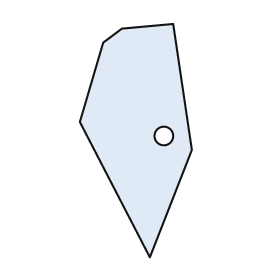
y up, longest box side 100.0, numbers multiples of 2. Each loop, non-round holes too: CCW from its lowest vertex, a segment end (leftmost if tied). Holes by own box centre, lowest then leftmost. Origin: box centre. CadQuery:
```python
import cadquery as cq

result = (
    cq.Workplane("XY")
    .moveTo(6.0, -50.0)
    .lineTo(24.0, -4.0)
    .lineTo(16.0, 50.0)
    .lineTo(-6.0, 48.0)
    .lineTo(-14.0, 42.0)
    .lineTo(-24.0, 8.0)
    .close()
    .moveTo(12.0, 2.0)
    .circle(4.0)
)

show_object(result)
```